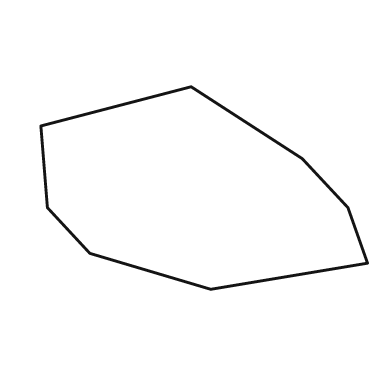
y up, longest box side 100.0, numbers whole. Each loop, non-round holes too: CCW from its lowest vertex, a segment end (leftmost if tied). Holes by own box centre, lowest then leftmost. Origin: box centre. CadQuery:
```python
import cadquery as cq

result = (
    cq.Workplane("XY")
    .moveTo(2.0, -31.0)
    .lineTo(50.0, -23.0)
    .lineTo(44.0, -6.0)
    .lineTo(30.0, 9.0)
    .lineTo(-4.0, 31.0)
    .lineTo(-50.0, 19.0)
    .lineTo(-48.0, -6.0)
    .lineTo(-35.0, -20.0)
    .close()
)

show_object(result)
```